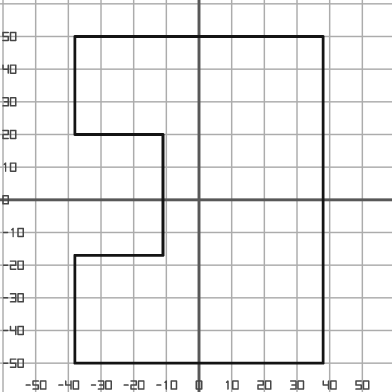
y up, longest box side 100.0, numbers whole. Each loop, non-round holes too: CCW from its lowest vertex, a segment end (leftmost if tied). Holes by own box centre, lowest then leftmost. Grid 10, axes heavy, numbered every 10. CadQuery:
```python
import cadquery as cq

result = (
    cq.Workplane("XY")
    .moveTo(-38.0, -50.0)
    .lineTo(38.0, -50.0)
    .lineTo(38.0, 50.0)
    .lineTo(-38.0, 50.0)
    .lineTo(-38.0, 20.0)
    .lineTo(-11.0, 20.0)
    .lineTo(-11.0, -17.0)
    .lineTo(-38.0, -17.0)
    .close()
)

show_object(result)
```